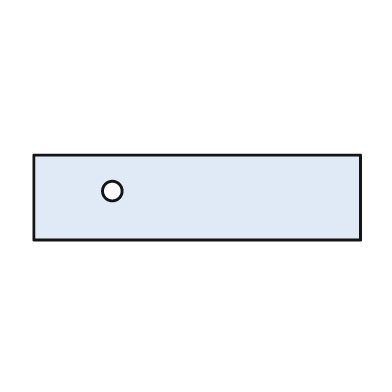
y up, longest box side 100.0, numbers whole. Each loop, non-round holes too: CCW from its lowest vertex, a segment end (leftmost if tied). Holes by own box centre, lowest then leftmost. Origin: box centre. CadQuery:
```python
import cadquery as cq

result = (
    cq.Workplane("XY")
    .moveTo(-50.0, -13.0)
    .lineTo(50.0, -13.0)
    .lineTo(50.0, 13.0)
    .lineTo(-50.0, 13.0)
    .close()
    .moveTo(-26.0, 2.0)
    .circle(3.0)
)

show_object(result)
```